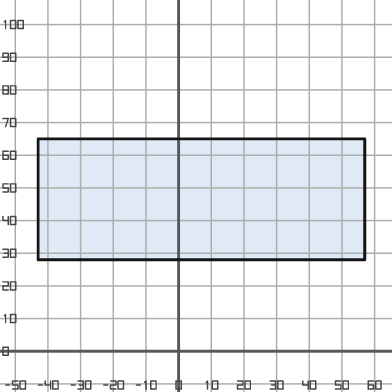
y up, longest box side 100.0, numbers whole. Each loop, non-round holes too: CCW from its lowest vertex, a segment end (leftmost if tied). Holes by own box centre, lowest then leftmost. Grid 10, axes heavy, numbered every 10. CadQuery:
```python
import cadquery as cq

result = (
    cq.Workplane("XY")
    .moveTo(-43.0, 28.0)
    .lineTo(57.0, 28.0)
    .lineTo(57.0, 65.0)
    .lineTo(-43.0, 65.0)
    .close()
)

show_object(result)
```